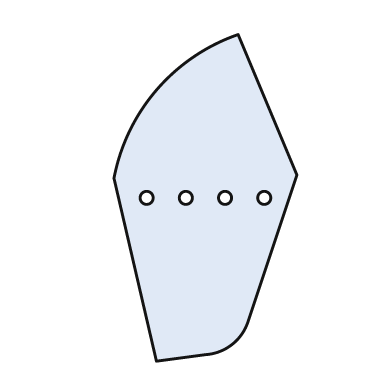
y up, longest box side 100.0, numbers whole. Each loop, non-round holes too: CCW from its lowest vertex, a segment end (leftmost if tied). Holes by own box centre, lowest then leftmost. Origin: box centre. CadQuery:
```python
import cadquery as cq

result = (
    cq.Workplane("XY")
    .moveTo(-15.0, -50.0)
    .lineTo(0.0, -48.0)
    .threePointArc((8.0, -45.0), (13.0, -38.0))
    .lineTo(28.0, 7.0)
    .lineTo(10.0, 50.0)
    .threePointArc((-15.0, 33.0), (-28.0, 6.0))
    .close()
    .moveTo(-18.0, 0.0)
    .circle(2.0)
    .moveTo(-6.0, 0.0)
    .circle(2.0)
    .moveTo(6.0, 0.0)
    .circle(2.0)
    .moveTo(18.0, 0.0)
    .circle(2.0)
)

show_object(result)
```